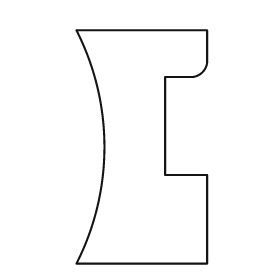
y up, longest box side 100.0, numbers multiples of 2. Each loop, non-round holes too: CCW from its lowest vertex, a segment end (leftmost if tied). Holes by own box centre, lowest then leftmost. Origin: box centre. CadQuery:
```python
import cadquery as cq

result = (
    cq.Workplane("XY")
    .moveTo(-28.0, -50.0)
    .lineTo(28.0, -50.0)
    .lineTo(28.0, -12.0)
    .lineTo(10.0, -12.0)
    .lineTo(10.0, 30.0)
    .lineTo(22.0, 30.0)
    .threePointArc((26.0, 32.0), (28.0, 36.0))
    .lineTo(28.0, 50.0)
    .lineTo(-28.0, 50.0)
    .threePointArc((-16.0, 0.0), (-28.0, -50.0))
    .close()
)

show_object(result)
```